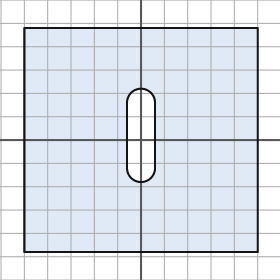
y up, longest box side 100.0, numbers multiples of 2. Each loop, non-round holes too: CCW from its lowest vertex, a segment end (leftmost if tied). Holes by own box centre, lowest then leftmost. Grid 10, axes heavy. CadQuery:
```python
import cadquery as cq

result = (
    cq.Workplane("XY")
    .moveTo(-50.0, -48.0)
    .lineTo(50.0, -48.0)
    .lineTo(50.0, 48.0)
    .lineTo(-50.0, 48.0)
    .close()
    .moveTo(-6.0, -12.0)
    .threePointArc((0.0, -18.0), (6.0, -12.0))
    .lineTo(6.0, 16.0)
    .threePointArc((0.0, 22.0), (-6.0, 16.0))
    .close()
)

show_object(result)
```